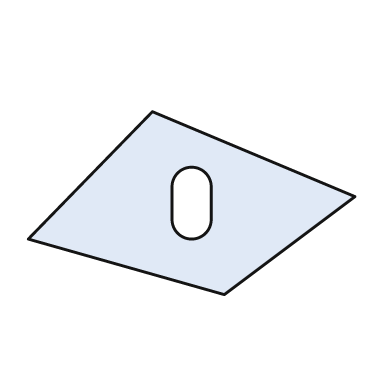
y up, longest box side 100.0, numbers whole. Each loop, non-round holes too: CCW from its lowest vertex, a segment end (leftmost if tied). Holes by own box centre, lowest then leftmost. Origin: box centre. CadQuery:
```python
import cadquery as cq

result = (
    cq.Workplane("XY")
    .moveTo(10.0, -28.0)
    .lineTo(50.0, 2.0)
    .lineTo(-12.0, 28.0)
    .lineTo(-50.0, -11.0)
    .close()
    .moveTo(-6.0, -5.0)
    .threePointArc((0.0, -11.0), (6.0, -5.0))
    .lineTo(6.0, 5.0)
    .threePointArc((0.0, 11.0), (-6.0, 5.0))
    .close()
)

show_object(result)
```